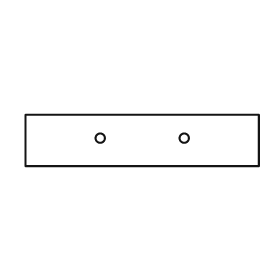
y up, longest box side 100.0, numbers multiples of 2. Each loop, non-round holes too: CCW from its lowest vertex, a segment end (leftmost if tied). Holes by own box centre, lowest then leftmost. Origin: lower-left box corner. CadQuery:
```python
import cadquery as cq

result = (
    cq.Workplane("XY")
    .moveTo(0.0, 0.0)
    .lineTo(100.0, 0.0)
    .lineTo(100.0, 22.0)
    .lineTo(0.0, 22.0)
    .close()
    .moveTo(32.0, 12.0)
    .circle(2.0)
    .moveTo(68.0, 12.0)
    .circle(2.0)
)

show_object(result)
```